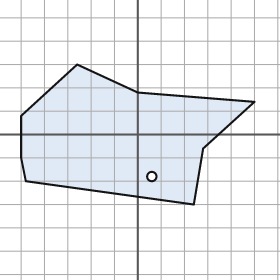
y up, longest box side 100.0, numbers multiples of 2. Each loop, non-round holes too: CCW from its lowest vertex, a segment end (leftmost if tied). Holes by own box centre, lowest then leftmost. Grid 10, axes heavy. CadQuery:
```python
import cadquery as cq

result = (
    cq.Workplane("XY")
    .moveTo(24.0, -30.0)
    .lineTo(28.0, -6.0)
    .lineTo(50.0, 14.0)
    .lineTo(0.0, 18.0)
    .lineTo(-26.0, 30.0)
    .lineTo(-50.0, 8.0)
    .lineTo(-50.0, -10.0)
    .lineTo(-48.0, -20.0)
    .close()
    .moveTo(6.0, -18.0)
    .circle(2.0)
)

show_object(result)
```